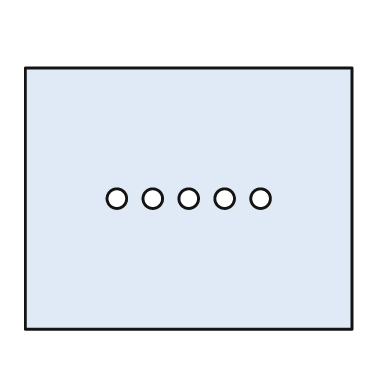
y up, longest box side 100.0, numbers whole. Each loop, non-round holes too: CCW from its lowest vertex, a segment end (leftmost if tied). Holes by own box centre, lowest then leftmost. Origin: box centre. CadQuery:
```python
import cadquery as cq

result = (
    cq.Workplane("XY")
    .moveTo(-50.0, -40.0)
    .lineTo(50.0, -40.0)
    .lineTo(50.0, 40.0)
    .lineTo(-50.0, 40.0)
    .close()
    .moveTo(-22.0, 0.0)
    .circle(3.0)
    .moveTo(-11.0, 0.0)
    .circle(3.0)
    .moveTo(0.0, 0.0)
    .circle(3.0)
    .moveTo(11.0, 0.0)
    .circle(3.0)
    .moveTo(22.0, 0.0)
    .circle(3.0)
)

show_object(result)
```